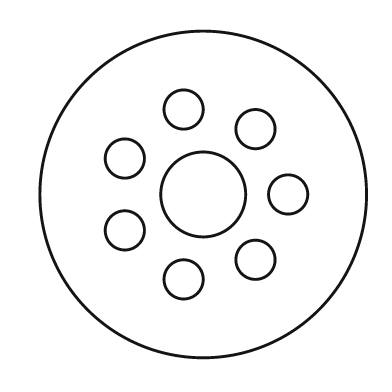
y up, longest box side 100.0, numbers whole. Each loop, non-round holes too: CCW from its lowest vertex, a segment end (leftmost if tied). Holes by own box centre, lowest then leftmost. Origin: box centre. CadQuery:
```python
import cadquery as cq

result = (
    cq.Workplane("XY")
    .moveTo(0.0, 0.0)
    .circle(50.0)
    .moveTo(-6.0, -26.0)
    .circle(6.0)
    .moveTo(16.0, -20.0)
    .circle(6.0)
    .moveTo(-24.0, -11.0)
    .circle(6.0)
    .moveTo(0.0, 0.0)
    .circle(13.0)
    .moveTo(26.0, 0.0)
    .circle(6.0)
    .moveTo(-24.0, 11.0)
    .circle(6.0)
    .moveTo(16.0, 20.0)
    .circle(6.0)
    .moveTo(-6.0, 26.0)
    .circle(6.0)
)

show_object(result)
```